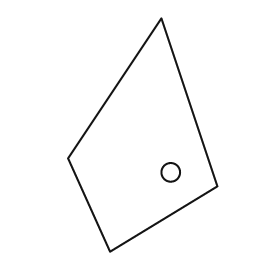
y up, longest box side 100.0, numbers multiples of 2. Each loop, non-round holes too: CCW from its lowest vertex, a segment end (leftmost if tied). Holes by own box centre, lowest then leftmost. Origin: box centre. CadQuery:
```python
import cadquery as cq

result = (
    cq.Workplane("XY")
    .moveTo(-14.0, -50.0)
    .lineTo(32.0, -22.0)
    .lineTo(8.0, 50.0)
    .lineTo(-32.0, -10.0)
    .close()
    .moveTo(12.0, -16.0)
    .circle(4.0)
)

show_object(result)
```